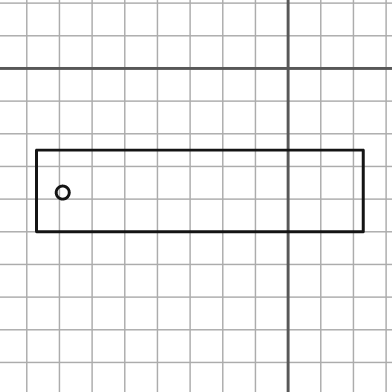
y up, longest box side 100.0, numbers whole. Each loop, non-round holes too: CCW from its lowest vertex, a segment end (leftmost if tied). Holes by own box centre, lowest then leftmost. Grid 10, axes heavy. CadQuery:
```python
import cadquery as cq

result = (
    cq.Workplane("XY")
    .moveTo(-77.0, -50.0)
    .lineTo(23.0, -50.0)
    .lineTo(23.0, -25.0)
    .lineTo(-77.0, -25.0)
    .close()
    .moveTo(-69.0, -38.0)
    .circle(2.0)
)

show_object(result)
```